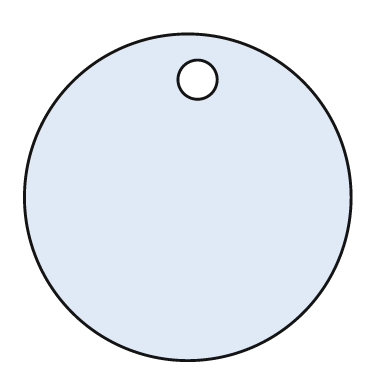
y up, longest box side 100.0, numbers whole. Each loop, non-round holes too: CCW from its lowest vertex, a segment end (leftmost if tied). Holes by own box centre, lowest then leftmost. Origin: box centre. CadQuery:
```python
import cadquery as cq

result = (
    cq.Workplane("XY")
    .moveTo(0.0, 0.0)
    .circle(50.0)
    .moveTo(3.0, 36.0)
    .circle(6.0)
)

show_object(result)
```